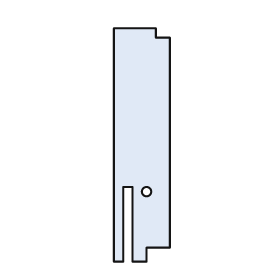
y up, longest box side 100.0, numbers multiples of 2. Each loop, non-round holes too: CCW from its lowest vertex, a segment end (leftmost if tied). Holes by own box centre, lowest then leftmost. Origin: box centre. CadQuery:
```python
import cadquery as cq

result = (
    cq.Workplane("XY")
    .moveTo(-12.0, -50.0)
    .lineTo(-8.0, -50.0)
    .lineTo(-8.0, -18.0)
    .lineTo(-4.0, -18.0)
    .lineTo(-4.0, -50.0)
    .lineTo(2.0, -50.0)
    .lineTo(2.0, -44.0)
    .lineTo(12.0, -44.0)
    .lineTo(12.0, 46.0)
    .lineTo(6.0, 46.0)
    .lineTo(6.0, 50.0)
    .lineTo(-12.0, 50.0)
    .close()
    .moveTo(2.0, -20.0)
    .circle(2.0)
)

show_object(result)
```